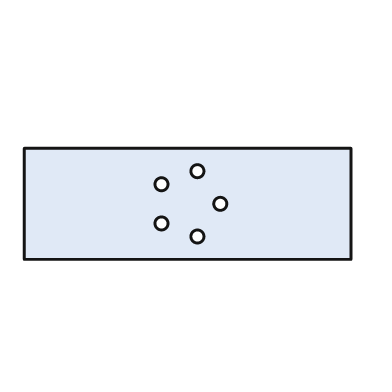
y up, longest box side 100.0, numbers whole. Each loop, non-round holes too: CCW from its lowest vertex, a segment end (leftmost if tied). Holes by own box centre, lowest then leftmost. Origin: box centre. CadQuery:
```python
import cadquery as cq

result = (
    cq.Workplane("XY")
    .moveTo(-50.0, -17.0)
    .lineTo(50.0, -17.0)
    .lineTo(50.0, 17.0)
    .lineTo(-50.0, 17.0)
    .close()
    .moveTo(3.0, -10.0)
    .circle(2.0)
    .moveTo(-8.0, -6.0)
    .circle(2.0)
    .moveTo(10.0, 0.0)
    .circle(2.0)
    .moveTo(-8.0, 6.0)
    .circle(2.0)
    .moveTo(3.0, 10.0)
    .circle(2.0)
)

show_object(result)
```